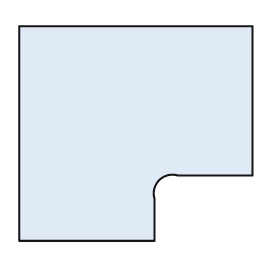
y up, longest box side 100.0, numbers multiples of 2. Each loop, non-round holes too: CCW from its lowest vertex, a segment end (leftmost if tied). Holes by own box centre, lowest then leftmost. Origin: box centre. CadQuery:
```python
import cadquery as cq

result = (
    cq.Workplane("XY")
    .moveTo(-50.0, -46.0)
    .lineTo(8.0, -46.0)
    .lineTo(8.0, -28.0)
    .threePointArc((10.0, -20.0), (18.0, -18.0))
    .lineTo(50.0, -18.0)
    .lineTo(50.0, 46.0)
    .lineTo(-50.0, 46.0)
    .close()
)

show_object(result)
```